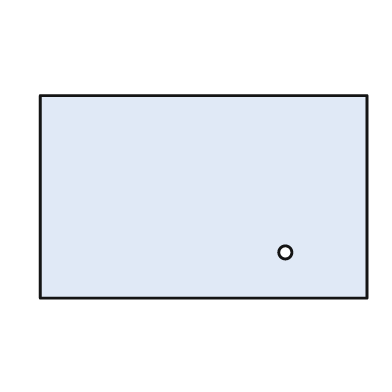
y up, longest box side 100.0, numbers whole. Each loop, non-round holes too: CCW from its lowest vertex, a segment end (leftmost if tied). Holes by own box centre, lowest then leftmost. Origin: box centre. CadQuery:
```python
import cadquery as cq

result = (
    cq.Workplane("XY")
    .moveTo(-50.0, -31.0)
    .lineTo(50.0, -31.0)
    .lineTo(50.0, 31.0)
    .lineTo(-50.0, 31.0)
    .close()
    .moveTo(25.0, -17.0)
    .circle(2.0)
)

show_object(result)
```